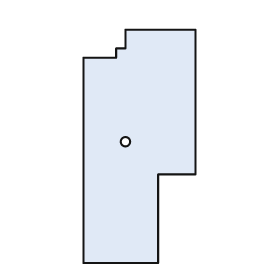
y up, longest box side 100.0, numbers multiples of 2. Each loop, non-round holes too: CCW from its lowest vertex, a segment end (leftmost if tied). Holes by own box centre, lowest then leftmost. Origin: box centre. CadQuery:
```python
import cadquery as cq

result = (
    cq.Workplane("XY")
    .moveTo(-24.0, -50.0)
    .lineTo(8.0, -50.0)
    .lineTo(8.0, -12.0)
    .lineTo(24.0, -12.0)
    .lineTo(24.0, 50.0)
    .lineTo(-6.0, 50.0)
    .lineTo(-6.0, 42.0)
    .lineTo(-10.0, 42.0)
    .lineTo(-10.0, 38.0)
    .lineTo(-24.0, 38.0)
    .close()
    .moveTo(-6.0, 2.0)
    .circle(2.0)
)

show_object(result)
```